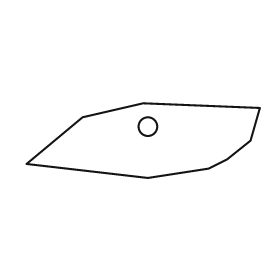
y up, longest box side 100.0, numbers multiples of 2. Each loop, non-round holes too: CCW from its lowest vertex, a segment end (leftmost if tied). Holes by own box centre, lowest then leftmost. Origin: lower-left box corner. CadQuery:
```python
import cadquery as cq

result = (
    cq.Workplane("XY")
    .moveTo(52.0, 0.0)
    .lineTo(78.0, 4.0)
    .lineTo(86.0, 8.0)
    .lineTo(96.0, 16.0)
    .lineTo(100.0, 30.0)
    .lineTo(50.0, 32.0)
    .lineTo(24.0, 26.0)
    .lineTo(0.0, 6.0)
    .close()
    .moveTo(52.0, 22.0)
    .circle(4.0)
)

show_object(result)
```